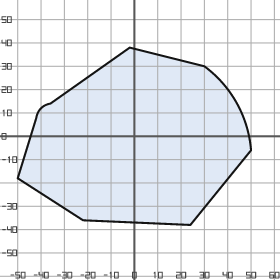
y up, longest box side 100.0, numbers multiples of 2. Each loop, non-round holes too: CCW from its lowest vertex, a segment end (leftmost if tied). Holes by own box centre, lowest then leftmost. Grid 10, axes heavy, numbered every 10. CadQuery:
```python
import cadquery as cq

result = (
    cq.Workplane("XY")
    .moveTo(24.0, -38.0)
    .lineTo(50.0, -6.0)
    .threePointArc((44.0, 14.0), (30.0, 30.0))
    .lineTo(-2.0, 38.0)
    .lineTo(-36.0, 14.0)
    .threePointArc((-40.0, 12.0), (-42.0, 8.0))
    .lineTo(-50.0, -18.0)
    .lineTo(-22.0, -36.0)
    .close()
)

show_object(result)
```